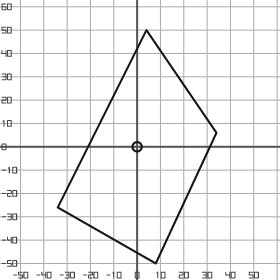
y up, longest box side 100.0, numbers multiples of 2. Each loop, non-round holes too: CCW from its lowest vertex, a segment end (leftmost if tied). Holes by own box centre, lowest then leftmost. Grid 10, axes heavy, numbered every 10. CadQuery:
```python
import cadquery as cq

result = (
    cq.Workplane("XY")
    .moveTo(8.0, -50.0)
    .lineTo(34.0, 6.0)
    .lineTo(4.0, 50.0)
    .lineTo(-34.0, -26.0)
    .close()
    .moveTo(0.0, 0.0)
    .circle(2.0)
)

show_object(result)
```